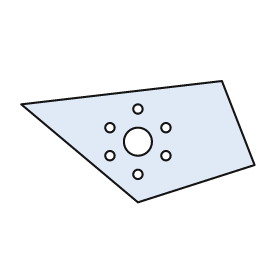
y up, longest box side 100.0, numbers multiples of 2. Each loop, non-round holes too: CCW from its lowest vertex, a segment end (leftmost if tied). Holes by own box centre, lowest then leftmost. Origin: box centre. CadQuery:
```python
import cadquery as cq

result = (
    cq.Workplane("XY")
    .moveTo(0.0, -26.0)
    .lineTo(50.0, -10.0)
    .lineTo(36.0, 26.0)
    .lineTo(-50.0, 16.0)
    .close()
    .moveTo(0.0, -14.0)
    .circle(2.0)
    .moveTo(-12.0, -6.0)
    .circle(2.0)
    .moveTo(12.0, -6.0)
    .circle(2.0)
    .moveTo(0.0, 0.0)
    .circle(6.0)
    .moveTo(-12.0, 6.0)
    .circle(2.0)
    .moveTo(12.0, 6.0)
    .circle(2.0)
    .moveTo(0.0, 14.0)
    .circle(2.0)
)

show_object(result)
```